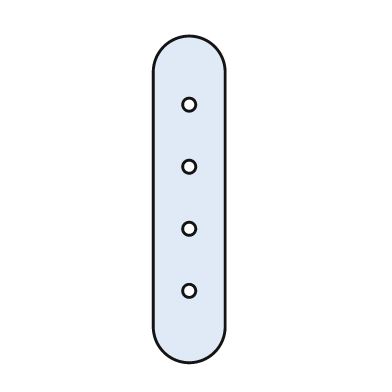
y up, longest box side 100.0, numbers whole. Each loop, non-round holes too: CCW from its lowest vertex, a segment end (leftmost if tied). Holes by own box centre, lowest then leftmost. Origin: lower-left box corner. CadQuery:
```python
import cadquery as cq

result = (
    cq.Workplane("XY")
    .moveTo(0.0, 11.0)
    .threePointArc((11.0, 0.0), (22.0, 11.0))
    .lineTo(22.0, 89.0)
    .threePointArc((11.0, 100.0), (0.0, 89.0))
    .close()
    .moveTo(11.0, 22.0)
    .circle(2.0)
    .moveTo(11.0, 41.0)
    .circle(2.0)
    .moveTo(11.0, 60.0)
    .circle(2.0)
    .moveTo(11.0, 79.0)
    .circle(2.0)
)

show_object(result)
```